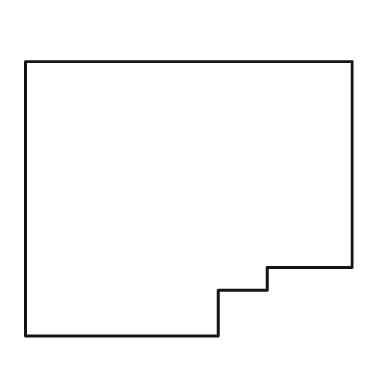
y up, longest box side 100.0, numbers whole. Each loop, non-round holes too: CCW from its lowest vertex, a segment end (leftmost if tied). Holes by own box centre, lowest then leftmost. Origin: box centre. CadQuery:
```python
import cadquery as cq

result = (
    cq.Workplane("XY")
    .moveTo(-50.0, -42.0)
    .lineTo(9.0, -42.0)
    .lineTo(9.0, -28.0)
    .lineTo(24.0, -28.0)
    .lineTo(24.0, -21.0)
    .lineTo(50.0, -21.0)
    .lineTo(50.0, 42.0)
    .lineTo(-50.0, 42.0)
    .close()
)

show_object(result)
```